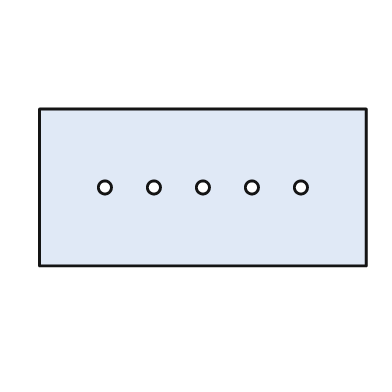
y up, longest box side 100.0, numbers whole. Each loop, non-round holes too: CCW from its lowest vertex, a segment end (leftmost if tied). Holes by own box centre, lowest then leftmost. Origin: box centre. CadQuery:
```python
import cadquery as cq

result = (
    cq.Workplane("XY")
    .moveTo(-50.0, -24.0)
    .lineTo(50.0, -24.0)
    .lineTo(50.0, 24.0)
    .lineTo(-50.0, 24.0)
    .close()
    .moveTo(-30.0, 0.0)
    .circle(2.0)
    .moveTo(-15.0, 0.0)
    .circle(2.0)
    .moveTo(0.0, 0.0)
    .circle(2.0)
    .moveTo(15.0, 0.0)
    .circle(2.0)
    .moveTo(30.0, 0.0)
    .circle(2.0)
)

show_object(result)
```